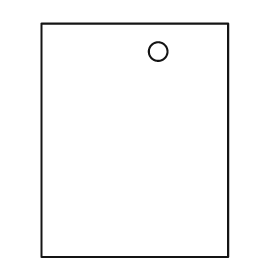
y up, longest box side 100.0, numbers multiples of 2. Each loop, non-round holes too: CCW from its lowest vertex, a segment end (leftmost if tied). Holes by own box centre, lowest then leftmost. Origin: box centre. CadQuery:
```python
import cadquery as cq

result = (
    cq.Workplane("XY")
    .moveTo(-40.0, -50.0)
    .lineTo(40.0, -50.0)
    .lineTo(40.0, 50.0)
    .lineTo(-40.0, 50.0)
    .close()
    .moveTo(10.0, 38.0)
    .circle(4.0)
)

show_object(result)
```